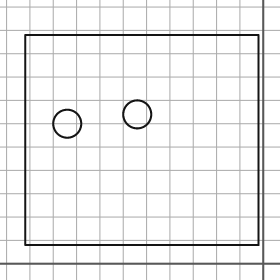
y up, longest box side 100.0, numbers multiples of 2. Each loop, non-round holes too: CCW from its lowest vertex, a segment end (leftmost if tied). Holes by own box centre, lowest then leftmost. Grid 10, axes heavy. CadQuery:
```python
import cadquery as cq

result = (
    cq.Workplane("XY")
    .moveTo(-102.0, 8.0)
    .lineTo(-2.0, 8.0)
    .lineTo(-2.0, 98.0)
    .lineTo(-102.0, 98.0)
    .close()
    .moveTo(-84.0, 60.0)
    .circle(6.0)
    .moveTo(-54.0, 64.0)
    .circle(6.0)
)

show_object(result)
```